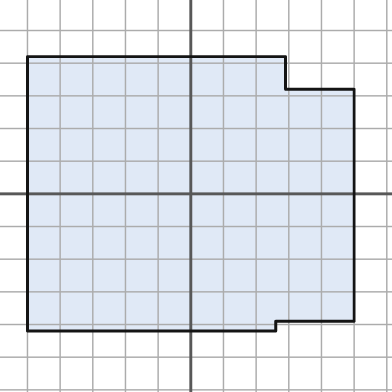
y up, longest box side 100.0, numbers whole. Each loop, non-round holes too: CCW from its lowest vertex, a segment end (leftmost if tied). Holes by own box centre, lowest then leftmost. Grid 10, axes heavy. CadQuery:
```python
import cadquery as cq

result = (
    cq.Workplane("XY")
    .moveTo(-50.0, -42.0)
    .lineTo(26.0, -42.0)
    .lineTo(26.0, -39.0)
    .lineTo(50.0, -39.0)
    .lineTo(50.0, 32.0)
    .lineTo(29.0, 32.0)
    .lineTo(29.0, 42.0)
    .lineTo(-50.0, 42.0)
    .close()
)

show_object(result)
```